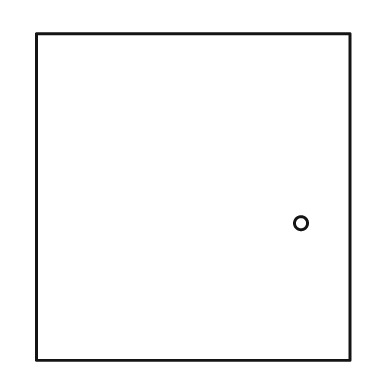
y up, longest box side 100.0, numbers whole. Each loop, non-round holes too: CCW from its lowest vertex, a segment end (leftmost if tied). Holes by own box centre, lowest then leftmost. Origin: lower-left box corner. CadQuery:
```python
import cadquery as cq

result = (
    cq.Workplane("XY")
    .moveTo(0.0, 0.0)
    .lineTo(96.0, 0.0)
    .lineTo(96.0, 100.0)
    .lineTo(0.0, 100.0)
    .close()
    .moveTo(81.0, 42.0)
    .circle(2.0)
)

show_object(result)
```